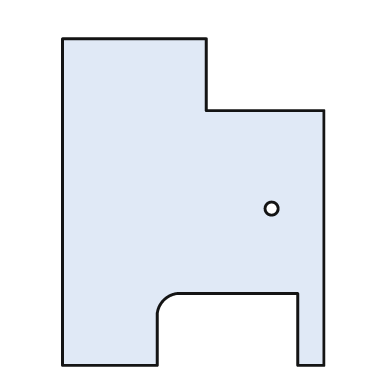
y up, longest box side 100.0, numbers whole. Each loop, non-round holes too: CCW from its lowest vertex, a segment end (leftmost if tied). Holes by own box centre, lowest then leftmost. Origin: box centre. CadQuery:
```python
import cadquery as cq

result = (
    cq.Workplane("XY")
    .moveTo(-40.0, -50.0)
    .lineTo(-11.0, -50.0)
    .lineTo(-11.0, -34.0)
    .threePointArc((-9.0, -30.0), (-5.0, -28.0))
    .lineTo(32.0, -28.0)
    .lineTo(32.0, -50.0)
    .lineTo(40.0, -50.0)
    .lineTo(40.0, 28.0)
    .lineTo(4.0, 28.0)
    .lineTo(4.0, 50.0)
    .lineTo(-40.0, 50.0)
    .close()
    .moveTo(24.0, -2.0)
    .circle(2.0)
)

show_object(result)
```